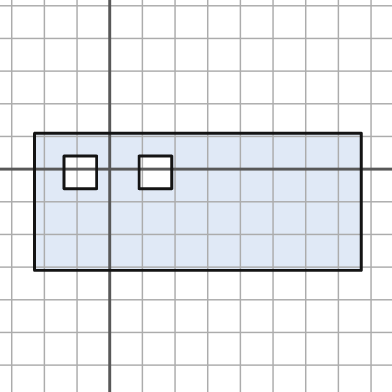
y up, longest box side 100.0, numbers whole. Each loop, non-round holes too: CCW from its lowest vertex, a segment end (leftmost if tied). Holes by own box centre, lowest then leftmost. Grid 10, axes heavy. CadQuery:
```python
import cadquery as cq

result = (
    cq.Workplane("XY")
    .moveTo(-23.0, -31.0)
    .lineTo(77.0, -31.0)
    .lineTo(77.0, 11.0)
    .lineTo(-23.0, 11.0)
    .close()
    .moveTo(-14.0, -6.0)
    .lineTo(-4.0, -6.0)
    .lineTo(-4.0, 4.0)
    .lineTo(-14.0, 4.0)
    .close()
    .moveTo(9.0, -6.0)
    .lineTo(19.0, -6.0)
    .lineTo(19.0, 4.0)
    .lineTo(9.0, 4.0)
    .close()
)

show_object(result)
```